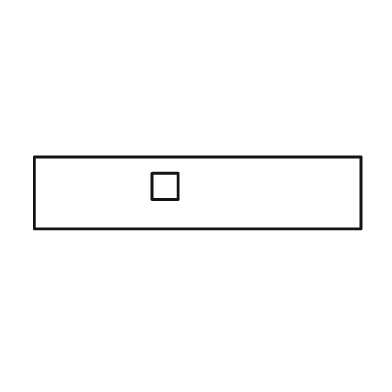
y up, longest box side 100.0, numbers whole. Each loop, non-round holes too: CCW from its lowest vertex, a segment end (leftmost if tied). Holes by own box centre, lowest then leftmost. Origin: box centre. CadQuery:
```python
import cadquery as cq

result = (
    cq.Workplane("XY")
    .moveTo(-50.0, -11.0)
    .lineTo(50.0, -11.0)
    .lineTo(50.0, 11.0)
    .lineTo(-50.0, 11.0)
    .close()
    .moveTo(-14.0, -2.0)
    .lineTo(-6.0, -2.0)
    .lineTo(-6.0, 6.0)
    .lineTo(-14.0, 6.0)
    .close()
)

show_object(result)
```